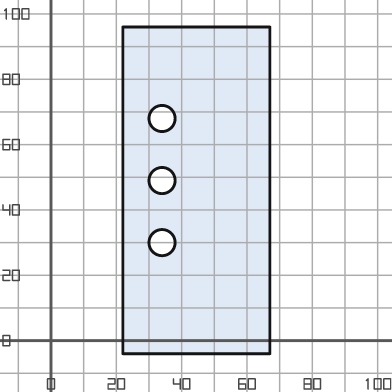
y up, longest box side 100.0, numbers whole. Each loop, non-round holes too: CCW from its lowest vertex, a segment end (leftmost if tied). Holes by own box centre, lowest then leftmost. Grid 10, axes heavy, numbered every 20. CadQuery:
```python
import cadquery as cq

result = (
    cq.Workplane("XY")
    .moveTo(22.0, -4.0)
    .lineTo(67.0, -4.0)
    .lineTo(67.0, 96.0)
    .lineTo(22.0, 96.0)
    .close()
    .moveTo(34.0, 30.0)
    .circle(4.0)
    .moveTo(34.0, 49.0)
    .circle(4.0)
    .moveTo(34.0, 68.0)
    .circle(4.0)
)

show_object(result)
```